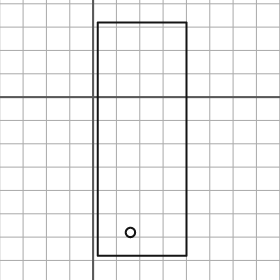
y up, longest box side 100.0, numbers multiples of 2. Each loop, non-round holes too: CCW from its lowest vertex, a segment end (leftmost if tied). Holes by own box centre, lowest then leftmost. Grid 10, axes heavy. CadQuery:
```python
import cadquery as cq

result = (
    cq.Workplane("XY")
    .moveTo(2.0, -68.0)
    .lineTo(40.0, -68.0)
    .lineTo(40.0, 32.0)
    .lineTo(2.0, 32.0)
    .close()
    .moveTo(16.0, -58.0)
    .circle(2.0)
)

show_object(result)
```